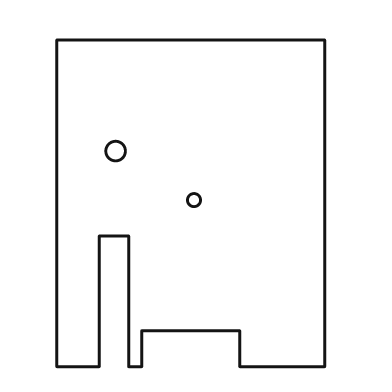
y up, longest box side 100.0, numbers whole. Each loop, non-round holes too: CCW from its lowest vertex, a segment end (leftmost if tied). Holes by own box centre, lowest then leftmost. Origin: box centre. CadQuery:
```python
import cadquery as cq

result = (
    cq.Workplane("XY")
    .moveTo(-41.0, -50.0)
    .lineTo(-28.0, -50.0)
    .lineTo(-28.0, -10.0)
    .lineTo(-19.0, -10.0)
    .lineTo(-19.0, -50.0)
    .lineTo(-15.0, -50.0)
    .lineTo(-15.0, -39.0)
    .lineTo(15.0, -39.0)
    .lineTo(15.0, -50.0)
    .lineTo(41.0, -50.0)
    .lineTo(41.0, 50.0)
    .lineTo(-41.0, 50.0)
    .close()
    .moveTo(1.0, 1.0)
    .circle(2.0)
    .moveTo(-23.0, 16.0)
    .circle(3.0)
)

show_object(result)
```